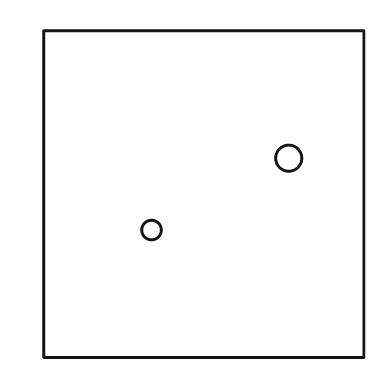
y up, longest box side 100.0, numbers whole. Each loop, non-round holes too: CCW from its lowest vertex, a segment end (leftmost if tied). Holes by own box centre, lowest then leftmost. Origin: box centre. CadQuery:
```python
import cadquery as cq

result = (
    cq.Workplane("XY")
    .moveTo(-49.0, -50.0)
    .lineTo(49.0, -50.0)
    .lineTo(49.0, 50.0)
    .lineTo(-49.0, 50.0)
    .close()
    .moveTo(-16.0, -11.0)
    .circle(3.0)
    .moveTo(26.0, 11.0)
    .circle(4.0)
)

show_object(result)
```